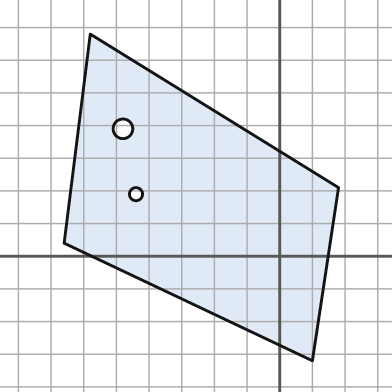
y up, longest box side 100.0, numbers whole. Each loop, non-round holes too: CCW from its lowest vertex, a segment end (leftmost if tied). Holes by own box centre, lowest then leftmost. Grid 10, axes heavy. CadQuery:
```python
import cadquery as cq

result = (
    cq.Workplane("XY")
    .moveTo(10.0, -32.0)
    .lineTo(18.0, 21.0)
    .lineTo(-58.0, 68.0)
    .lineTo(-66.0, 4.0)
    .close()
    .moveTo(-44.0, 19.0)
    .circle(2.0)
    .moveTo(-48.0, 39.0)
    .circle(3.0)
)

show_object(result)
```